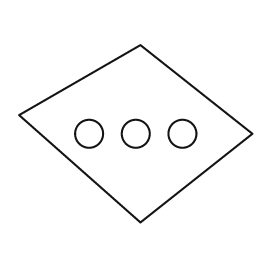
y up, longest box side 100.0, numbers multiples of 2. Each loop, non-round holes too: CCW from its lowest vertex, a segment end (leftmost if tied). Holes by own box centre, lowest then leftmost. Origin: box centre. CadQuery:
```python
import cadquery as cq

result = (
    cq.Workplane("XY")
    .moveTo(2.0, -38.0)
    .lineTo(50.0, 0.0)
    .lineTo(2.0, 38.0)
    .lineTo(-50.0, 8.0)
    .close()
    .moveTo(-20.0, 0.0)
    .circle(6.0)
    .moveTo(0.0, 0.0)
    .circle(6.0)
    .moveTo(20.0, 0.0)
    .circle(6.0)
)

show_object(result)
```